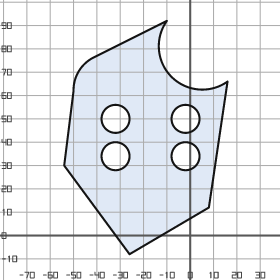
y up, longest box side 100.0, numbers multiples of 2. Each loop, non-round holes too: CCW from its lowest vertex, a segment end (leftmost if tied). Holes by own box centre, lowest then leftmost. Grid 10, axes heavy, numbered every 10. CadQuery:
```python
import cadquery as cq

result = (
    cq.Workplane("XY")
    .moveTo(-26.0, -8.0)
    .lineTo(8.0, 12.0)
    .lineTo(16.0, 66.0)
    .threePointArc((-8.0, 68.0), (-10.0, 92.0))
    .lineTo(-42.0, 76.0)
    .threePointArc((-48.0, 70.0), (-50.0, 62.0))
    .lineTo(-54.0, 30.0)
    .close()
    .moveTo(-32.0, 34.0)
    .circle(6.0)
    .moveTo(-2.0, 34.0)
    .circle(6.0)
    .moveTo(-32.0, 50.0)
    .circle(6.0)
    .moveTo(-2.0, 50.0)
    .circle(6.0)
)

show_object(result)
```